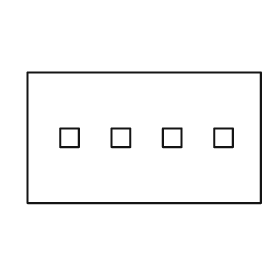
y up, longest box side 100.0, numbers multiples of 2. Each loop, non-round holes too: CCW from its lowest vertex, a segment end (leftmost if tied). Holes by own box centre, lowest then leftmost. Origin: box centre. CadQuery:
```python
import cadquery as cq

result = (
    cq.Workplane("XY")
    .moveTo(-50.0, -28.0)
    .lineTo(50.0, -28.0)
    .lineTo(50.0, 28.0)
    .lineTo(-50.0, 28.0)
    .close()
    .moveTo(-36.0, -4.0)
    .lineTo(-28.0, -4.0)
    .lineTo(-28.0, 4.0)
    .lineTo(-36.0, 4.0)
    .close()
    .moveTo(-14.0, -4.0)
    .lineTo(-6.0, -4.0)
    .lineTo(-6.0, 4.0)
    .lineTo(-14.0, 4.0)
    .close()
    .moveTo(8.0, -4.0)
    .lineTo(16.0, -4.0)
    .lineTo(16.0, 4.0)
    .lineTo(8.0, 4.0)
    .close()
    .moveTo(30.0, -4.0)
    .lineTo(38.0, -4.0)
    .lineTo(38.0, 4.0)
    .lineTo(30.0, 4.0)
    .close()
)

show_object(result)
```